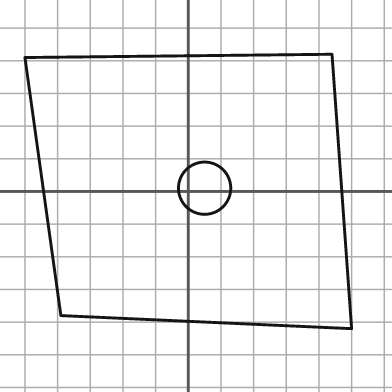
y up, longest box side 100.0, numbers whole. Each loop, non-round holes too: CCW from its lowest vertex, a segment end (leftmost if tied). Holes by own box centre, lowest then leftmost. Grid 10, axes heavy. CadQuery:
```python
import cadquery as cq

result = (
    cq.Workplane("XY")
    .moveTo(50.0, -42.0)
    .lineTo(44.0, 42.0)
    .lineTo(-50.0, 41.0)
    .lineTo(-39.0, -38.0)
    .close()
    .moveTo(5.0, 1.0)
    .circle(8.0)
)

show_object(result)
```